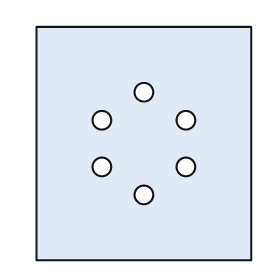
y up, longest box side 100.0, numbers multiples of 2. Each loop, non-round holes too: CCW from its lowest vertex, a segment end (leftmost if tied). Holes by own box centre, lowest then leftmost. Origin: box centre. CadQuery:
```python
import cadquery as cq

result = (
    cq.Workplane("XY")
    .moveTo(-46.0, -50.0)
    .lineTo(46.0, -50.0)
    .lineTo(46.0, 50.0)
    .lineTo(-46.0, 50.0)
    .close()
    .moveTo(0.0, -22.0)
    .circle(4.0)
    .moveTo(-18.0, -10.0)
    .circle(4.0)
    .moveTo(18.0, -10.0)
    .circle(4.0)
    .moveTo(-18.0, 10.0)
    .circle(4.0)
    .moveTo(18.0, 10.0)
    .circle(4.0)
    .moveTo(0.0, 22.0)
    .circle(4.0)
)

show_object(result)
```